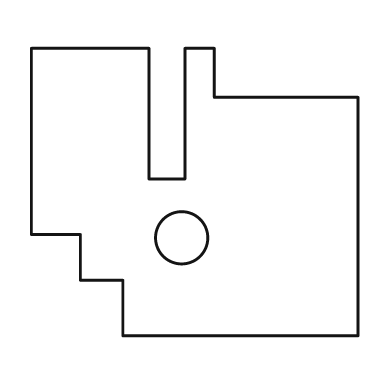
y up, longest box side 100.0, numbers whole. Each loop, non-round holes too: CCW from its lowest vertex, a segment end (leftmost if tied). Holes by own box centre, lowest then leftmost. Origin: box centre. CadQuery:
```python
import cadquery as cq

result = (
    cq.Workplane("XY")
    .moveTo(-22.0, -44.0)
    .lineTo(50.0, -44.0)
    .lineTo(50.0, 29.0)
    .lineTo(6.0, 29.0)
    .lineTo(6.0, 44.0)
    .lineTo(-3.0, 44.0)
    .lineTo(-3.0, 4.0)
    .lineTo(-14.0, 4.0)
    .lineTo(-14.0, 44.0)
    .lineTo(-50.0, 44.0)
    .lineTo(-50.0, -13.0)
    .lineTo(-35.0, -13.0)
    .lineTo(-35.0, -27.0)
    .lineTo(-22.0, -27.0)
    .close()
    .moveTo(-4.0, -14.0)
    .circle(8.0)
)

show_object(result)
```